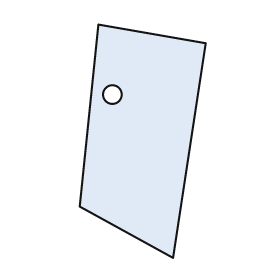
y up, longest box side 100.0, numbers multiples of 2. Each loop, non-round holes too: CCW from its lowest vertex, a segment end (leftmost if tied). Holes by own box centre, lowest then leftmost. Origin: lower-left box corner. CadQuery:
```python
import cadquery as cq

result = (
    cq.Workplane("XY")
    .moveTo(40.0, 0.0)
    .lineTo(54.0, 92.0)
    .lineTo(8.0, 100.0)
    .lineTo(0.0, 22.0)
    .close()
    .moveTo(14.0, 70.0)
    .circle(4.0)
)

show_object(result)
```